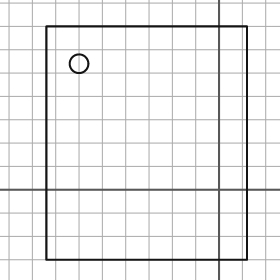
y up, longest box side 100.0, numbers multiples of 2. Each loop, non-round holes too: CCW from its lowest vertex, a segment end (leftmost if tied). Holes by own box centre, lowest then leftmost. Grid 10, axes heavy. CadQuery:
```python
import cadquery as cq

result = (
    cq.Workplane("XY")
    .moveTo(-74.0, -30.0)
    .lineTo(12.0, -30.0)
    .lineTo(12.0, 70.0)
    .lineTo(-74.0, 70.0)
    .close()
    .moveTo(-60.0, 54.0)
    .circle(4.0)
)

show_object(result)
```